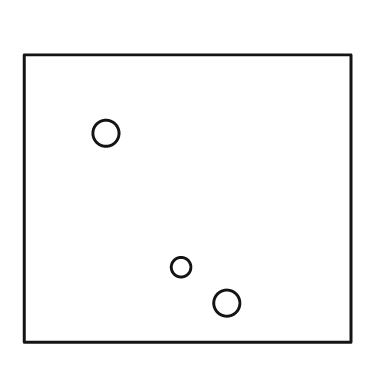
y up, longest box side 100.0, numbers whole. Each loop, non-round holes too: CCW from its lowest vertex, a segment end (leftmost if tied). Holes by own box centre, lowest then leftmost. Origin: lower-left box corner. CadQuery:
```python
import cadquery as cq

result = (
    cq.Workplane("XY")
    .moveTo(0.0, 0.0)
    .lineTo(100.0, 0.0)
    .lineTo(100.0, 88.0)
    .lineTo(0.0, 88.0)
    .close()
    .moveTo(62.0, 12.0)
    .circle(4.0)
    .moveTo(48.0, 23.0)
    .circle(3.0)
    .moveTo(25.0, 64.0)
    .circle(4.0)
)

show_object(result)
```